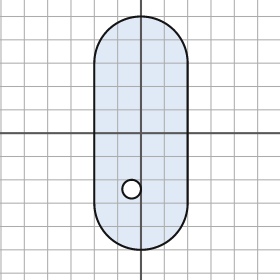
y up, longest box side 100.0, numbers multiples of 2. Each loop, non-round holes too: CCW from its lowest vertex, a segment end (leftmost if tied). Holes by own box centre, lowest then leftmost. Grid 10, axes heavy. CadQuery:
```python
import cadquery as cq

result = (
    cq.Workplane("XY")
    .moveTo(-20.0, -30.0)
    .threePointArc((0.0, -50.0), (20.0, -30.0))
    .lineTo(20.0, 30.0)
    .threePointArc((0.0, 50.0), (-20.0, 30.0))
    .close()
    .moveTo(-4.0, -24.0)
    .circle(4.0)
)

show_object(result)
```